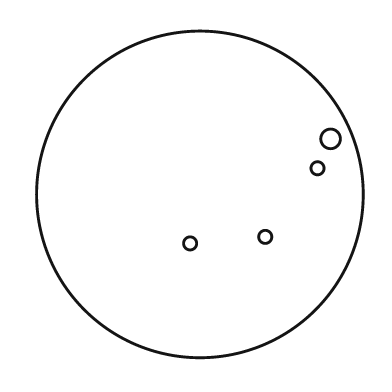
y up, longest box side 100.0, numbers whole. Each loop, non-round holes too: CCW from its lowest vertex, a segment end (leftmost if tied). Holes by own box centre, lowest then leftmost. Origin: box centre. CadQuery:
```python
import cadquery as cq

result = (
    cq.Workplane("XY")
    .moveTo(0.0, 0.0)
    .circle(50.0)
    .moveTo(-3.0, -15.0)
    .circle(2.0)
    .moveTo(20.0, -13.0)
    .circle(2.0)
    .moveTo(36.0, 8.0)
    .circle(2.0)
    .moveTo(40.0, 17.0)
    .circle(3.0)
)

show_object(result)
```